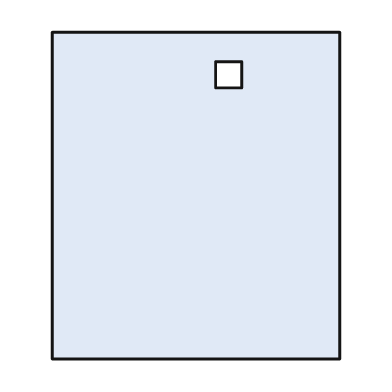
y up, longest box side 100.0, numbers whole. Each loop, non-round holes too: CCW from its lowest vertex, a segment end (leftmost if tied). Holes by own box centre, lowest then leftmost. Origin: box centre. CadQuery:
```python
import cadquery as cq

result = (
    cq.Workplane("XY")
    .moveTo(-44.0, -50.0)
    .lineTo(44.0, -50.0)
    .lineTo(44.0, 50.0)
    .lineTo(-44.0, 50.0)
    .close()
    .moveTo(6.0, 33.0)
    .lineTo(14.0, 33.0)
    .lineTo(14.0, 41.0)
    .lineTo(6.0, 41.0)
    .close()
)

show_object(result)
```